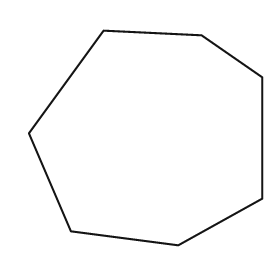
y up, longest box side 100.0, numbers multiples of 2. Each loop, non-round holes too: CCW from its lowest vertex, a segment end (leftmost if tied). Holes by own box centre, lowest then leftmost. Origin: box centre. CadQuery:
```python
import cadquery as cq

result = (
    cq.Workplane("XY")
    .moveTo(14.0, -46.0)
    .lineTo(50.0, -26.0)
    .lineTo(50.0, 26.0)
    .lineTo(24.0, 44.0)
    .lineTo(-18.0, 46.0)
    .lineTo(-50.0, 2.0)
    .lineTo(-32.0, -40.0)
    .close()
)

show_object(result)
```